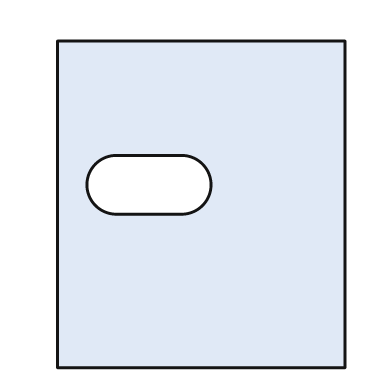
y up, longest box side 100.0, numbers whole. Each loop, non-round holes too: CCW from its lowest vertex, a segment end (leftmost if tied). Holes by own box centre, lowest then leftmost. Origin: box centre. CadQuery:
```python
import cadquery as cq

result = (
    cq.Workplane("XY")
    .moveTo(-44.0, -50.0)
    .lineTo(44.0, -50.0)
    .lineTo(44.0, 50.0)
    .lineTo(-44.0, 50.0)
    .close()
    .moveTo(-26.0, -3.0)
    .lineTo(-6.0, -3.0)
    .threePointArc((3.0, 6.0), (-6.0, 15.0))
    .lineTo(-26.0, 15.0)
    .threePointArc((-35.0, 6.0), (-26.0, -3.0))
    .close()
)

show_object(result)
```